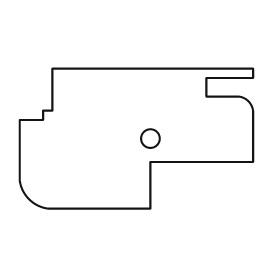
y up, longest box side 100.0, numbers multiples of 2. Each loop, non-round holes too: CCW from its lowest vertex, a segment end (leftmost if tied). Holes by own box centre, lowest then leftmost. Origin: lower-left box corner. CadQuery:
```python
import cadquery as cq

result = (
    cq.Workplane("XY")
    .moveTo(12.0, 0.0)
    .lineTo(56.0, 0.0)
    .lineTo(56.0, 20.0)
    .lineTo(100.0, 20.0)
    .lineTo(100.0, 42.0)
    .threePointArc((98.0, 46.0), (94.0, 48.0))
    .lineTo(80.0, 48.0)
    .lineTo(80.0, 56.0)
    .lineTo(100.0, 56.0)
    .lineTo(100.0, 60.0)
    .lineTo(14.0, 60.0)
    .lineTo(14.0, 42.0)
    .lineTo(10.0, 42.0)
    .lineTo(10.0, 38.0)
    .lineTo(0.0, 38.0)
    .lineTo(0.0, 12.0)
    .threePointArc((4.0, 4.0), (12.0, 0.0))
    .close()
    .moveTo(56.0, 30.0)
    .circle(4.0)
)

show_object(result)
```